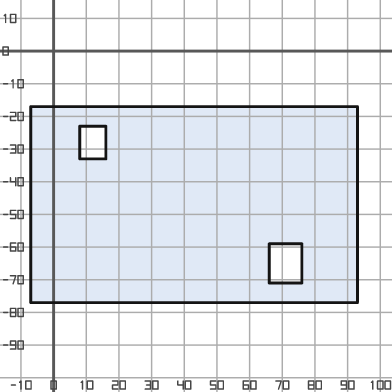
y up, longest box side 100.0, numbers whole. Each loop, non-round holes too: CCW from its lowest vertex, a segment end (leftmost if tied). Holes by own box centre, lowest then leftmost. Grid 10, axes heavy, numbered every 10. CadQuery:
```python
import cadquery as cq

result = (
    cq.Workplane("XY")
    .moveTo(-7.0, -77.0)
    .lineTo(93.0, -77.0)
    .lineTo(93.0, -17.0)
    .lineTo(-7.0, -17.0)
    .close()
    .moveTo(66.0, -71.0)
    .lineTo(76.0, -71.0)
    .lineTo(76.0, -59.0)
    .lineTo(66.0, -59.0)
    .close()
    .moveTo(8.0, -33.0)
    .lineTo(16.0, -33.0)
    .lineTo(16.0, -23.0)
    .lineTo(8.0, -23.0)
    .close()
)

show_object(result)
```